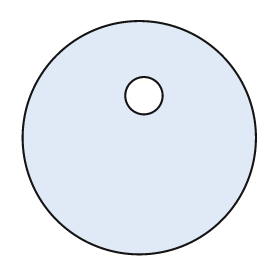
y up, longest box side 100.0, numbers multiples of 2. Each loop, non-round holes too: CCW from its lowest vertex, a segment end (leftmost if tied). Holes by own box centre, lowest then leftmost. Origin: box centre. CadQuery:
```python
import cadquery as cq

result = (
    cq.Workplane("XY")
    .moveTo(0.0, 0.0)
    .circle(50.0)
    .moveTo(2.0, 18.0)
    .circle(8.0)
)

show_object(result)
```